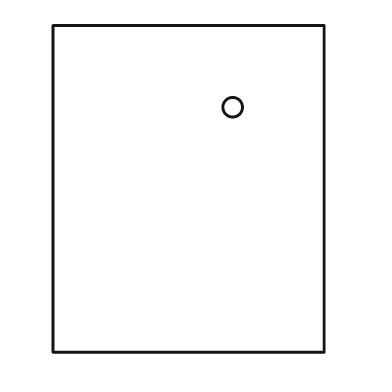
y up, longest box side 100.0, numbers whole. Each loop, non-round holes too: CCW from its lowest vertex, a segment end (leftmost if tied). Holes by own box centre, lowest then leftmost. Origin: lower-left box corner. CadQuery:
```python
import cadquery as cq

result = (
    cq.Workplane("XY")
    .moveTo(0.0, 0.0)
    .lineTo(83.0, 0.0)
    .lineTo(83.0, 100.0)
    .lineTo(0.0, 100.0)
    .close()
    .moveTo(55.0, 75.0)
    .circle(3.0)
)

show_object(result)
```